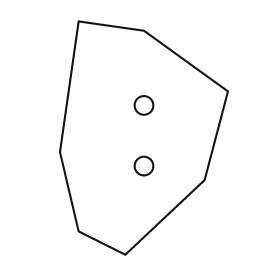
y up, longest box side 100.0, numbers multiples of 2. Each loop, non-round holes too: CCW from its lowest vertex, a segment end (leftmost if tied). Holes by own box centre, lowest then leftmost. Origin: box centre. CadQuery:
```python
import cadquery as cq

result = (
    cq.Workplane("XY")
    .moveTo(-8.0, -50.0)
    .lineTo(26.0, -18.0)
    .lineTo(36.0, 20.0)
    .lineTo(0.0, 46.0)
    .lineTo(-28.0, 50.0)
    .lineTo(-36.0, -6.0)
    .lineTo(-28.0, -40.0)
    .close()
    .moveTo(0.0, -12.0)
    .circle(4.0)
    .moveTo(0.0, 14.0)
    .circle(4.0)
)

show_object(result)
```